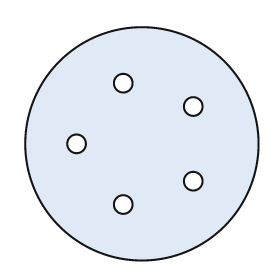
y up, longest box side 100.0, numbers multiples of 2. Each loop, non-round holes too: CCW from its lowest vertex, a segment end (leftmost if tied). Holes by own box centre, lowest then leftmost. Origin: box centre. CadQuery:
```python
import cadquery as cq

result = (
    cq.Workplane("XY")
    .moveTo(0.0, 0.0)
    .circle(50.0)
    .moveTo(-8.0, -26.0)
    .circle(4.0)
    .moveTo(22.0, -16.0)
    .circle(4.0)
    .moveTo(-28.0, 0.0)
    .circle(4.0)
    .moveTo(22.0, 16.0)
    .circle(4.0)
    .moveTo(-8.0, 26.0)
    .circle(4.0)
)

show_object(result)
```